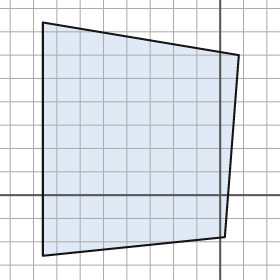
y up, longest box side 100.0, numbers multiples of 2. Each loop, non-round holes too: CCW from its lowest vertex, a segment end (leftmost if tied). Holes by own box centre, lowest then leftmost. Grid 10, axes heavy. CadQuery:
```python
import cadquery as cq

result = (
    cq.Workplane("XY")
    .moveTo(-76.0, -26.0)
    .lineTo(2.0, -18.0)
    .lineTo(8.0, 60.0)
    .lineTo(-76.0, 74.0)
    .close()
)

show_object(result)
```